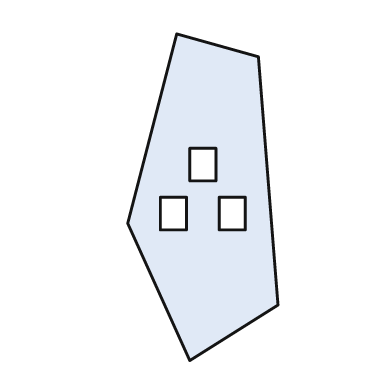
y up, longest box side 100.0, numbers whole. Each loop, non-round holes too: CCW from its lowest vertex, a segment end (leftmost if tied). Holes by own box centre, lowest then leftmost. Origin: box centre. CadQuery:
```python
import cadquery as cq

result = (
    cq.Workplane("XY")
    .moveTo(-4.0, -50.0)
    .lineTo(23.0, -33.0)
    .lineTo(17.0, 43.0)
    .lineTo(-8.0, 50.0)
    .lineTo(-23.0, -8.0)
    .close()
    .moveTo(-13.0, -10.0)
    .lineTo(-5.0, -10.0)
    .lineTo(-5.0, 0.0)
    .lineTo(-13.0, 0.0)
    .close()
    .moveTo(5.0, -10.0)
    .lineTo(13.0, -10.0)
    .lineTo(13.0, 0.0)
    .lineTo(5.0, 0.0)
    .close()
    .moveTo(-4.0, 5.0)
    .lineTo(4.0, 5.0)
    .lineTo(4.0, 15.0)
    .lineTo(-4.0, 15.0)
    .close()
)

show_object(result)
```